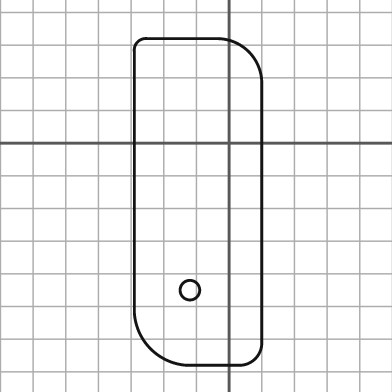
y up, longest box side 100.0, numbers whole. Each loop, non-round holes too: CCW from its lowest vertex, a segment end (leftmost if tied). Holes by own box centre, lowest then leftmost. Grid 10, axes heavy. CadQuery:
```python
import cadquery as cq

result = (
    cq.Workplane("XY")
    .moveTo(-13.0, -68.0)
    .lineTo(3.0, -68.0)
    .threePointArc((8.0, -66.0), (10.0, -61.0))
    .lineTo(10.0, 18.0)
    .threePointArc((6.0, 28.0), (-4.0, 32.0))
    .lineTo(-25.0, 32.0)
    .threePointArc((-28.0, 31.0), (-29.0, 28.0))
    .lineTo(-29.0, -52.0)
    .threePointArc((-24.0, -63.0), (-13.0, -68.0))
    .close()
    .moveTo(-12.0, -45.0)
    .circle(3.0)
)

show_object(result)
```